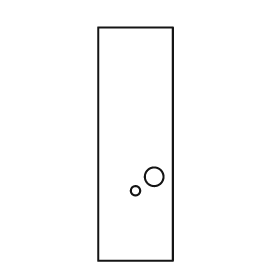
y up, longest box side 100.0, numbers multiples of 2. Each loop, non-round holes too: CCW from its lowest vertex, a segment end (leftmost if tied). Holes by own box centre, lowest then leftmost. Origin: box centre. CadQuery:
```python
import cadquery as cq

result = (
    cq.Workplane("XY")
    .moveTo(-16.0, -50.0)
    .lineTo(16.0, -50.0)
    .lineTo(16.0, 50.0)
    .lineTo(-16.0, 50.0)
    .close()
    .moveTo(0.0, -20.0)
    .circle(2.0)
    .moveTo(8.0, -14.0)
    .circle(4.0)
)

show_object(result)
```